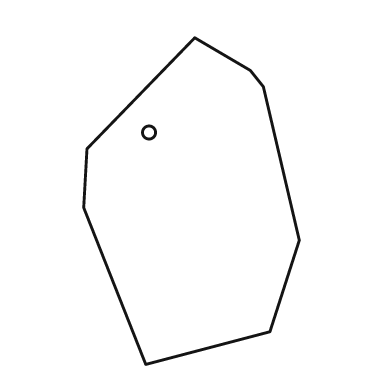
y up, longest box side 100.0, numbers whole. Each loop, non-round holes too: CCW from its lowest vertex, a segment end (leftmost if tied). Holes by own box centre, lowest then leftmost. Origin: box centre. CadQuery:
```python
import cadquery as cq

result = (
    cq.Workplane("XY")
    .moveTo(-14.0, -50.0)
    .lineTo(24.0, -40.0)
    .lineTo(33.0, -12.0)
    .lineTo(22.0, 35.0)
    .lineTo(18.0, 40.0)
    .lineTo(1.0, 50.0)
    .lineTo(-32.0, 16.0)
    .lineTo(-33.0, -2.0)
    .close()
    .moveTo(-13.0, 21.0)
    .circle(2.0)
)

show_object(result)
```